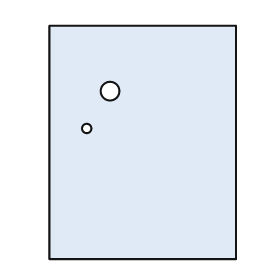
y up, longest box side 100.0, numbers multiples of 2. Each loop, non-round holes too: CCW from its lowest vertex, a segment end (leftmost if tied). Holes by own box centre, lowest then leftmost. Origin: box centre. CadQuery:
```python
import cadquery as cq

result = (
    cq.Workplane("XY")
    .moveTo(-40.0, -50.0)
    .lineTo(40.0, -50.0)
    .lineTo(40.0, 50.0)
    .lineTo(-40.0, 50.0)
    .close()
    .moveTo(-24.0, 6.0)
    .circle(2.0)
    .moveTo(-14.0, 22.0)
    .circle(4.0)
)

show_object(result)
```